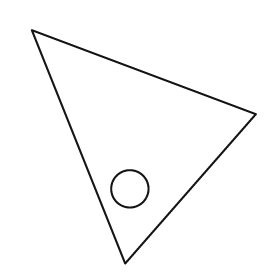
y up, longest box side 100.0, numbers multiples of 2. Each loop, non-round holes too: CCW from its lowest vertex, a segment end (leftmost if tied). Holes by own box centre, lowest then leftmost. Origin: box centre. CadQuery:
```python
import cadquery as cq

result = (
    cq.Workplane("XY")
    .moveTo(-8.0, -50.0)
    .lineTo(48.0, 14.0)
    .lineTo(-48.0, 50.0)
    .close()
    .moveTo(-6.0, -18.0)
    .circle(8.0)
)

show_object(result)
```